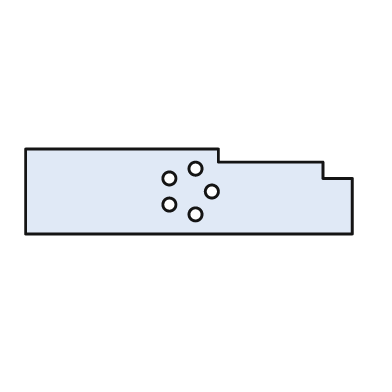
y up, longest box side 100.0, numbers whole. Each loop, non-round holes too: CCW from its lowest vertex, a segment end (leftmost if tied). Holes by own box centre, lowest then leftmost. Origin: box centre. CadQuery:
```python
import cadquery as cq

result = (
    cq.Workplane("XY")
    .moveTo(-50.0, -13.0)
    .lineTo(50.0, -13.0)
    .lineTo(50.0, 4.0)
    .lineTo(41.0, 4.0)
    .lineTo(41.0, 9.0)
    .lineTo(9.0, 9.0)
    .lineTo(9.0, 13.0)
    .lineTo(-50.0, 13.0)
    .close()
    .moveTo(2.0, -7.0)
    .circle(2.0)
    .moveTo(-6.0, -4.0)
    .circle(2.0)
    .moveTo(7.0, 0.0)
    .circle(2.0)
    .moveTo(-6.0, 4.0)
    .circle(2.0)
    .moveTo(2.0, 7.0)
    .circle(2.0)
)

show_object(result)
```